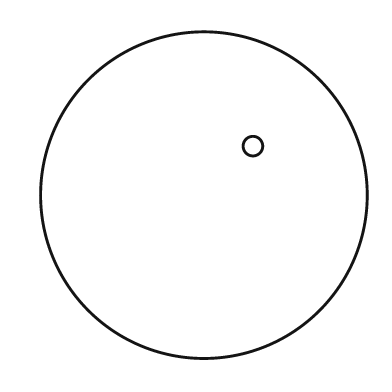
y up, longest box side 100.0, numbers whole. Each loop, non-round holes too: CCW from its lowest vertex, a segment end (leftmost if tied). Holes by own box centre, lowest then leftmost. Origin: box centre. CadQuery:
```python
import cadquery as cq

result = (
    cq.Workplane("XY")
    .moveTo(0.0, 0.0)
    .circle(50.0)
    .moveTo(15.0, 15.0)
    .circle(3.0)
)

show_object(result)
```